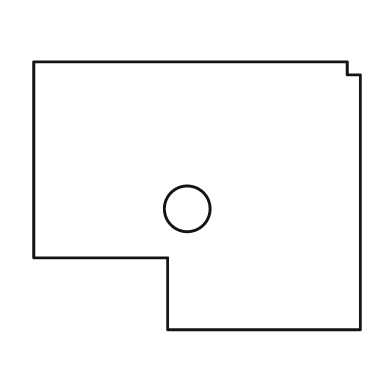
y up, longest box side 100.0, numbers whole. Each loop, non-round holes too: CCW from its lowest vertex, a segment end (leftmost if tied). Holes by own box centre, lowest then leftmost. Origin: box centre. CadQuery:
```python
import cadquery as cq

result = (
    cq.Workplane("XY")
    .moveTo(-9.0, -41.0)
    .lineTo(50.0, -41.0)
    .lineTo(50.0, 37.0)
    .lineTo(46.0, 37.0)
    .lineTo(46.0, 41.0)
    .lineTo(-50.0, 41.0)
    .lineTo(-50.0, -19.0)
    .lineTo(-9.0, -19.0)
    .close()
    .moveTo(-3.0, -4.0)
    .circle(7.0)
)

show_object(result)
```